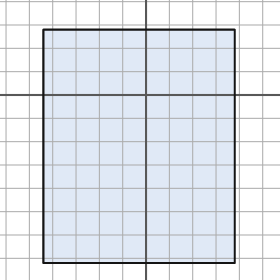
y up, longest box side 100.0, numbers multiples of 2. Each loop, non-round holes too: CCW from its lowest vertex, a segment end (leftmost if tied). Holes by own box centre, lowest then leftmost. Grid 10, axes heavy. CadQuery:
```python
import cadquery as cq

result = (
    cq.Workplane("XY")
    .moveTo(-44.0, -72.0)
    .lineTo(38.0, -72.0)
    .lineTo(38.0, 28.0)
    .lineTo(-44.0, 28.0)
    .close()
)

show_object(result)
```